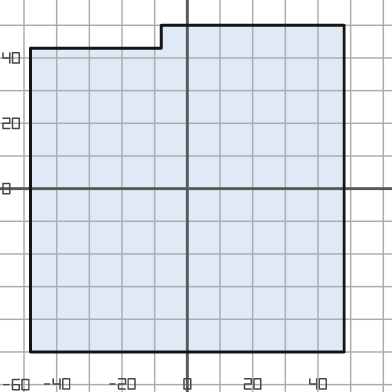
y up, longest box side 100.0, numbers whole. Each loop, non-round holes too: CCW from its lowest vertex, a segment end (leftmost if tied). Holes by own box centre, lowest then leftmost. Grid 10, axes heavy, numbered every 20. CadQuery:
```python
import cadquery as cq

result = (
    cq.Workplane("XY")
    .moveTo(-48.0, -50.0)
    .lineTo(48.0, -50.0)
    .lineTo(48.0, 50.0)
    .lineTo(-8.0, 50.0)
    .lineTo(-8.0, 43.0)
    .lineTo(-48.0, 43.0)
    .close()
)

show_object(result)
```